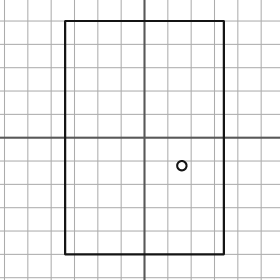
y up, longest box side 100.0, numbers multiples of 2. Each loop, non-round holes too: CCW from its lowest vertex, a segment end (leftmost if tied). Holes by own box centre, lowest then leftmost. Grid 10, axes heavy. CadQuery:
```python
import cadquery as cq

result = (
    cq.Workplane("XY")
    .moveTo(-34.0, -50.0)
    .lineTo(34.0, -50.0)
    .lineTo(34.0, 50.0)
    .lineTo(-34.0, 50.0)
    .close()
    .moveTo(16.0, -12.0)
    .circle(2.0)
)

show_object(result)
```